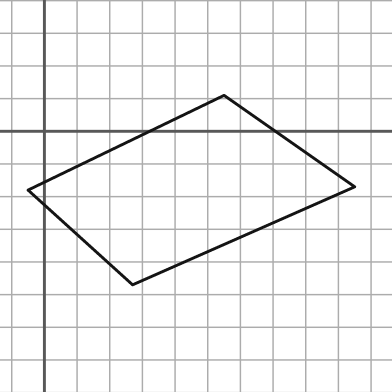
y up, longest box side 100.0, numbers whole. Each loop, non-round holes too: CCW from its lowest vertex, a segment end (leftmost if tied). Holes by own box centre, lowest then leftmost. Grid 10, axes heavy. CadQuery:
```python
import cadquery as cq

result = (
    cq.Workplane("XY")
    .moveTo(27.0, -47.0)
    .lineTo(95.0, -17.0)
    .lineTo(55.0, 11.0)
    .lineTo(-5.0, -18.0)
    .close()
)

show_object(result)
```